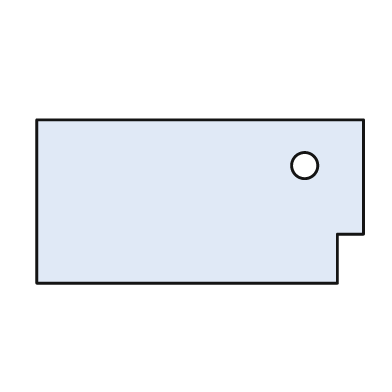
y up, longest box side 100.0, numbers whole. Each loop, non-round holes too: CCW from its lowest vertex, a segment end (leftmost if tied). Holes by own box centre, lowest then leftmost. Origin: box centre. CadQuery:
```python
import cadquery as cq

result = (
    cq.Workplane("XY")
    .moveTo(-50.0, -25.0)
    .lineTo(42.0, -25.0)
    .lineTo(42.0, -10.0)
    .lineTo(50.0, -10.0)
    .lineTo(50.0, 25.0)
    .lineTo(-50.0, 25.0)
    .close()
    .moveTo(32.0, 11.0)
    .circle(4.0)
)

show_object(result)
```